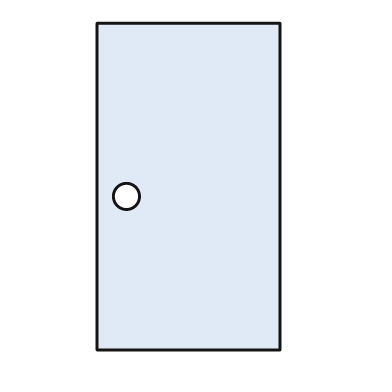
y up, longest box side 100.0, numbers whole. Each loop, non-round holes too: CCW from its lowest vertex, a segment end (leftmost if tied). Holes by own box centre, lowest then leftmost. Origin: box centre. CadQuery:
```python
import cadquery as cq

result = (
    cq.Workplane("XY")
    .moveTo(-28.0, -50.0)
    .lineTo(28.0, -50.0)
    .lineTo(28.0, 50.0)
    .lineTo(-28.0, 50.0)
    .close()
    .moveTo(-19.0, -3.0)
    .circle(4.0)
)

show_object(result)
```